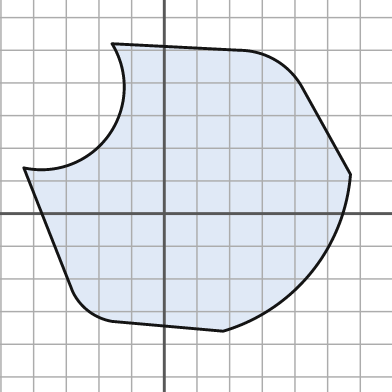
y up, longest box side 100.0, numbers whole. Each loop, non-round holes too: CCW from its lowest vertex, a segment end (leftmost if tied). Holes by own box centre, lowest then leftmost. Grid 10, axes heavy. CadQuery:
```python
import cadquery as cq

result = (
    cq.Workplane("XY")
    .moveTo(18.0, -36.0)
    .threePointArc((45.0, -18.0), (57.0, 12.0))
    .lineTo(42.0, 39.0)
    .threePointArc((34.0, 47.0), (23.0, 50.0))
    .lineTo(-16.0, 52.0)
    .threePointArc((-17.0, 24.0), (-43.0, 14.0))
    .lineTo(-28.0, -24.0)
    .threePointArc((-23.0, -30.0), (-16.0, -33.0))
    .close()
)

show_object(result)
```